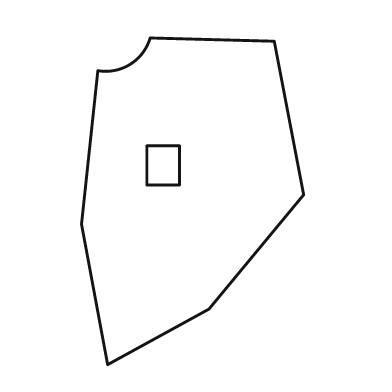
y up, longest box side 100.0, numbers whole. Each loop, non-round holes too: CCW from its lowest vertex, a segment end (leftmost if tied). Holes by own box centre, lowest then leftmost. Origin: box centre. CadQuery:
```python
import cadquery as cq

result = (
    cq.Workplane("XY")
    .moveTo(-26.0, -50.0)
    .lineTo(5.0, -33.0)
    .lineTo(34.0, 2.0)
    .lineTo(25.0, 49.0)
    .lineTo(-13.0, 50.0)
    .threePointArc((-19.0, 42.0), (-29.0, 40.0))
    .lineTo(-34.0, -7.0)
    .close()
    .moveTo(-14.0, 5.0)
    .lineTo(-4.0, 5.0)
    .lineTo(-4.0, 17.0)
    .lineTo(-14.0, 17.0)
    .close()
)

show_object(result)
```